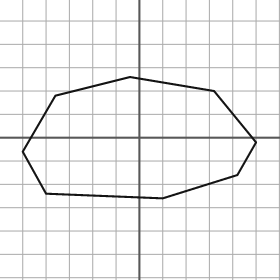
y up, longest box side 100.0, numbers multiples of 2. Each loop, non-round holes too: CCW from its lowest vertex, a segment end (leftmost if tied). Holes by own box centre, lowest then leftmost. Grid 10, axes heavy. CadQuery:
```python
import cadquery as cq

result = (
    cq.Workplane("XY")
    .moveTo(10.0, -26.0)
    .lineTo(42.0, -16.0)
    .lineTo(50.0, -2.0)
    .lineTo(32.0, 20.0)
    .lineTo(-4.0, 26.0)
    .lineTo(-36.0, 18.0)
    .lineTo(-50.0, -6.0)
    .lineTo(-40.0, -24.0)
    .close()
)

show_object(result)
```